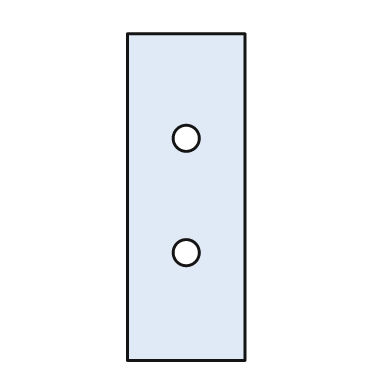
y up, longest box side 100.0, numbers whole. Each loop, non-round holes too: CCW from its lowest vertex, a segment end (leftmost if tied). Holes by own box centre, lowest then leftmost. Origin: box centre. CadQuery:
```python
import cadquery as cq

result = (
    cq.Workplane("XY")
    .moveTo(-18.0, -50.0)
    .lineTo(18.0, -50.0)
    .lineTo(18.0, 50.0)
    .lineTo(-18.0, 50.0)
    .close()
    .moveTo(0.0, -17.0)
    .circle(4.0)
    .moveTo(0.0, 18.0)
    .circle(4.0)
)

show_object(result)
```